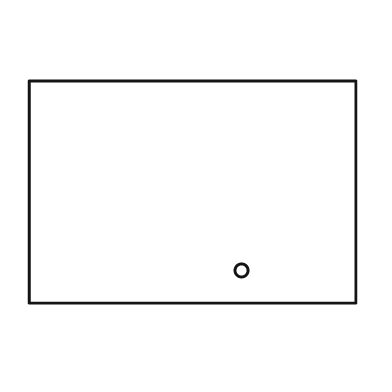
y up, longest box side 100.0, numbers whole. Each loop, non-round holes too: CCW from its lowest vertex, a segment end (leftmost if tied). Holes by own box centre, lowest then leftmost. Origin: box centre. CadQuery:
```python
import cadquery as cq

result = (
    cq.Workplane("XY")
    .moveTo(-50.0, -34.0)
    .lineTo(50.0, -34.0)
    .lineTo(50.0, 34.0)
    .lineTo(-50.0, 34.0)
    .close()
    .moveTo(15.0, -24.0)
    .circle(2.0)
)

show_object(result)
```